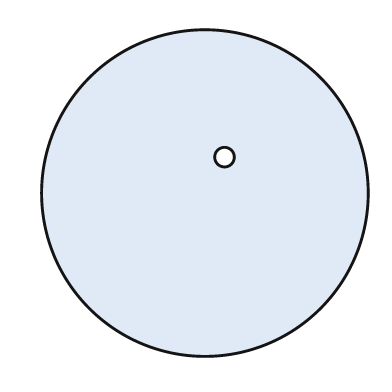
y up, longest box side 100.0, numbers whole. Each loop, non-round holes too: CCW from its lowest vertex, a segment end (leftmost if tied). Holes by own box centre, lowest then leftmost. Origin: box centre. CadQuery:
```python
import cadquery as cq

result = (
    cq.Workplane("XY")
    .moveTo(0.0, 0.0)
    .circle(50.0)
    .moveTo(6.0, 11.0)
    .circle(3.0)
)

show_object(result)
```